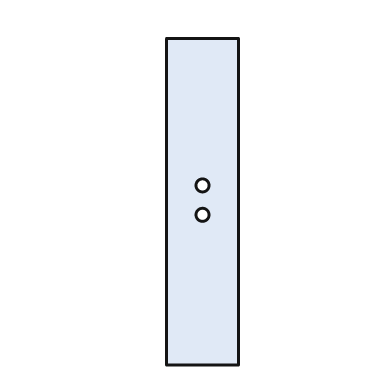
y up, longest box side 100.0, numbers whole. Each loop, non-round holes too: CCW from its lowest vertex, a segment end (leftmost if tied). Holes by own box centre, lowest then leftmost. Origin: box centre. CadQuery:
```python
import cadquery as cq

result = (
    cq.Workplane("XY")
    .moveTo(-11.0, -50.0)
    .lineTo(11.0, -50.0)
    .lineTo(11.0, 50.0)
    .lineTo(-11.0, 50.0)
    .close()
    .moveTo(0.0, -4.0)
    .circle(2.0)
    .moveTo(0.0, 5.0)
    .circle(2.0)
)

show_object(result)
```